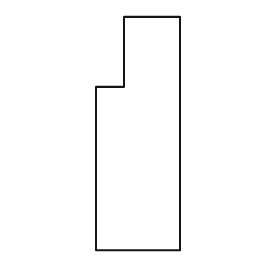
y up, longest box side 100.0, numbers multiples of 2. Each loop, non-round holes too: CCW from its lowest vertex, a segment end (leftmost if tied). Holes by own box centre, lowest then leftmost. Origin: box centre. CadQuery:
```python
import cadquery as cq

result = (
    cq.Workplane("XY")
    .moveTo(-18.0, -50.0)
    .lineTo(18.0, -50.0)
    .lineTo(18.0, 50.0)
    .lineTo(-6.0, 50.0)
    .lineTo(-6.0, 20.0)
    .lineTo(-18.0, 20.0)
    .close()
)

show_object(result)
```